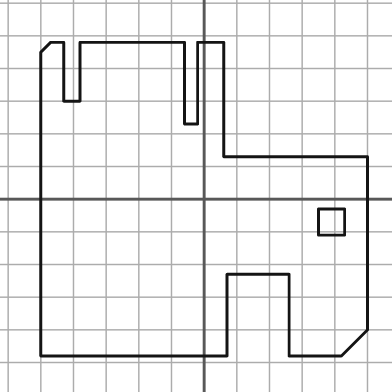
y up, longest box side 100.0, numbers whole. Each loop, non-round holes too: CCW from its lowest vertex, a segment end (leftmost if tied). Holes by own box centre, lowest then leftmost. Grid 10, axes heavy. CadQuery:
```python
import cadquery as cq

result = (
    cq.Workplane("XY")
    .moveTo(-50.0, -48.0)
    .lineTo(7.0, -48.0)
    .lineTo(7.0, -23.0)
    .lineTo(26.0, -23.0)
    .lineTo(26.0, -48.0)
    .lineTo(42.0, -48.0)
    .lineTo(50.0, -40.0)
    .lineTo(50.0, 13.0)
    .lineTo(6.0, 13.0)
    .lineTo(6.0, 48.0)
    .lineTo(-2.0, 48.0)
    .lineTo(-2.0, 23.0)
    .lineTo(-6.0, 23.0)
    .lineTo(-6.0, 48.0)
    .lineTo(-38.0, 48.0)
    .lineTo(-38.0, 30.0)
    .lineTo(-43.0, 30.0)
    .lineTo(-43.0, 48.0)
    .lineTo(-47.0, 48.0)
    .lineTo(-50.0, 45.0)
    .close()
    .moveTo(35.0, -11.0)
    .lineTo(43.0, -11.0)
    .lineTo(43.0, -3.0)
    .lineTo(35.0, -3.0)
    .close()
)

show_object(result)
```